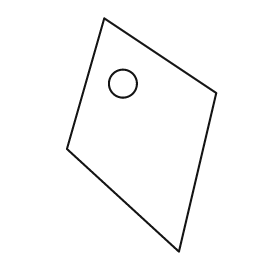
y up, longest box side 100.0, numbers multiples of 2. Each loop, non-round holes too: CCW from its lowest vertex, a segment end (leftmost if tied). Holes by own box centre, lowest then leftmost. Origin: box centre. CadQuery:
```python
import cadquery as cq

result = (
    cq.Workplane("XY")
    .moveTo(16.0, -50.0)
    .lineTo(32.0, 18.0)
    .lineTo(-16.0, 50.0)
    .lineTo(-32.0, -6.0)
    .close()
    .moveTo(-8.0, 22.0)
    .circle(6.0)
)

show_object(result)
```